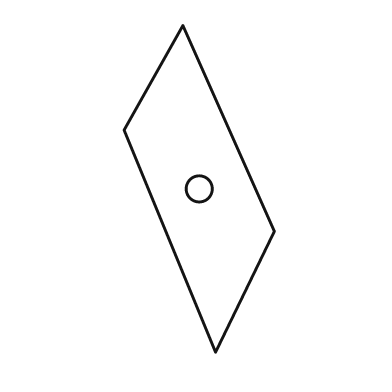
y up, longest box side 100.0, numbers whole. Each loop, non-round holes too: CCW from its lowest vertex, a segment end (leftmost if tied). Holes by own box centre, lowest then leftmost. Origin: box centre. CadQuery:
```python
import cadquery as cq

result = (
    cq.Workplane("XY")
    .moveTo(5.0, -50.0)
    .lineTo(23.0, -13.0)
    .lineTo(-5.0, 50.0)
    .lineTo(-23.0, 18.0)
    .close()
    .moveTo(0.0, 0.0)
    .circle(4.0)
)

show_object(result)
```